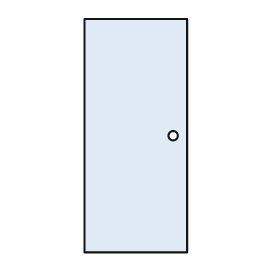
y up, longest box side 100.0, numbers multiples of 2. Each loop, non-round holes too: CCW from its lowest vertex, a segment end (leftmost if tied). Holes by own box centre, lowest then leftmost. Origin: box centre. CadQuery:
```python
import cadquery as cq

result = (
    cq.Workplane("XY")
    .moveTo(-22.0, -50.0)
    .lineTo(22.0, -50.0)
    .lineTo(22.0, 50.0)
    .lineTo(-22.0, 50.0)
    .close()
    .moveTo(16.0, 0.0)
    .circle(2.0)
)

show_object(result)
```